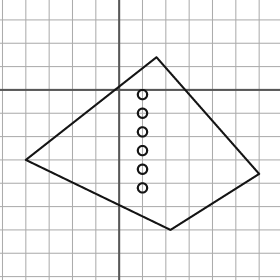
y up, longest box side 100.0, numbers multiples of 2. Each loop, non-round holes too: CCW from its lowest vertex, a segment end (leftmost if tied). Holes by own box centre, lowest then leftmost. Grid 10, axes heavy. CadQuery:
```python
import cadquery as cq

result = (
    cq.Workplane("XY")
    .moveTo(22.0, -60.0)
    .lineTo(60.0, -36.0)
    .lineTo(16.0, 14.0)
    .lineTo(-40.0, -30.0)
    .close()
    .moveTo(10.0, -42.0)
    .circle(2.0)
    .moveTo(10.0, -34.0)
    .circle(2.0)
    .moveTo(10.0, -26.0)
    .circle(2.0)
    .moveTo(10.0, -18.0)
    .circle(2.0)
    .moveTo(10.0, -10.0)
    .circle(2.0)
    .moveTo(10.0, -2.0)
    .circle(2.0)
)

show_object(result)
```